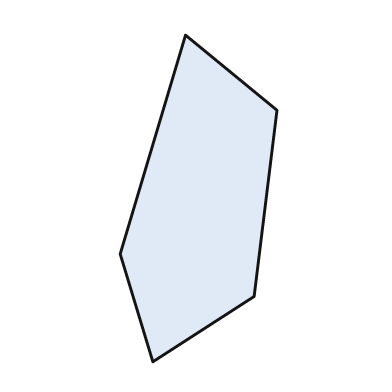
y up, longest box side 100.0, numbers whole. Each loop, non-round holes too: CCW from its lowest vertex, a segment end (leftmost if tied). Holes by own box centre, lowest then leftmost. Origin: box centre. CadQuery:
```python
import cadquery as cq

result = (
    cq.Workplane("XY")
    .moveTo(-14.0, -50.0)
    .lineTo(17.0, -30.0)
    .lineTo(24.0, 27.0)
    .lineTo(-4.0, 50.0)
    .lineTo(-24.0, -17.0)
    .close()
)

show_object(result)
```